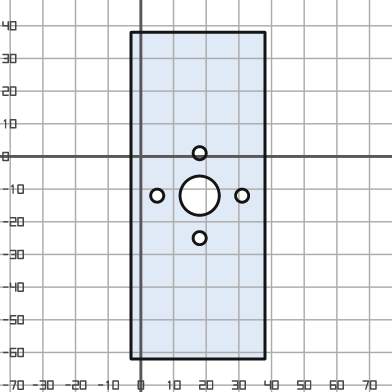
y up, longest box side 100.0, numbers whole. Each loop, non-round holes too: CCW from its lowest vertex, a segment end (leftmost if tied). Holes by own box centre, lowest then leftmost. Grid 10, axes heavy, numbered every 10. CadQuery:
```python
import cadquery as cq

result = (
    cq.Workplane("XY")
    .moveTo(-3.0, -62.0)
    .lineTo(38.0, -62.0)
    .lineTo(38.0, 38.0)
    .lineTo(-3.0, 38.0)
    .close()
    .moveTo(18.0, -25.0)
    .circle(2.0)
    .moveTo(5.0, -12.0)
    .circle(2.0)
    .moveTo(18.0, -12.0)
    .circle(6.0)
    .moveTo(31.0, -12.0)
    .circle(2.0)
    .moveTo(18.0, 1.0)
    .circle(2.0)
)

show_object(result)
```